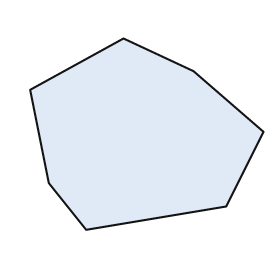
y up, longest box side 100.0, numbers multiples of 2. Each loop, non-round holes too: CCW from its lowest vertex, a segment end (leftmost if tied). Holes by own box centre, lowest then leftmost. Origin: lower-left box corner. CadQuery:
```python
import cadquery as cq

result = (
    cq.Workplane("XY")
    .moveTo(24.0, 0.0)
    .lineTo(84.0, 10.0)
    .lineTo(100.0, 42.0)
    .lineTo(70.0, 68.0)
    .lineTo(40.0, 82.0)
    .lineTo(0.0, 60.0)
    .lineTo(8.0, 20.0)
    .close()
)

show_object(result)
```